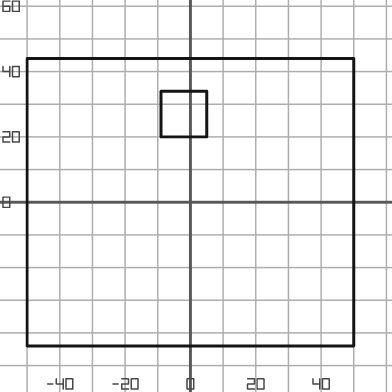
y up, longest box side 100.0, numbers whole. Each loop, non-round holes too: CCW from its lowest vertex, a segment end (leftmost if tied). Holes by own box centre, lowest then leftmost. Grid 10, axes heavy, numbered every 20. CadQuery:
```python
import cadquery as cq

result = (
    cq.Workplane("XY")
    .moveTo(-50.0, -44.0)
    .lineTo(50.0, -44.0)
    .lineTo(50.0, 44.0)
    .lineTo(-50.0, 44.0)
    .close()
    .moveTo(-9.0, 20.0)
    .lineTo(5.0, 20.0)
    .lineTo(5.0, 34.0)
    .lineTo(-9.0, 34.0)
    .close()
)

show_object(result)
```